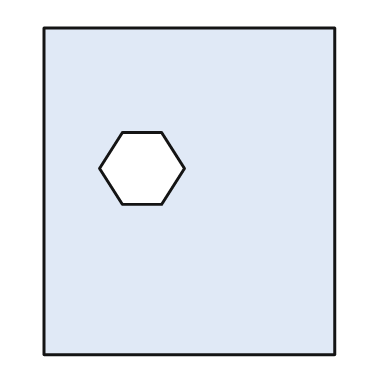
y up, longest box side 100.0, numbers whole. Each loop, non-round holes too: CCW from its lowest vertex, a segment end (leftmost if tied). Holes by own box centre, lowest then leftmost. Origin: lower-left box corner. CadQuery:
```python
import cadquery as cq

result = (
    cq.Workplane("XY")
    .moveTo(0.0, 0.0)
    .lineTo(89.0, 0.0)
    .lineTo(89.0, 100.0)
    .lineTo(0.0, 100.0)
    .close()
    .moveTo(24.0, 46.0)
    .lineTo(36.0, 46.0)
    .lineTo(43.0, 57.0)
    .lineTo(36.0, 68.0)
    .lineTo(24.0, 68.0)
    .lineTo(17.0, 57.0)
    .close()
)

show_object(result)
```